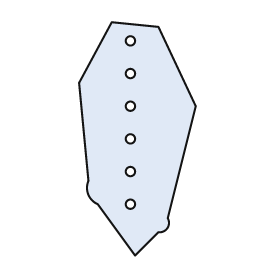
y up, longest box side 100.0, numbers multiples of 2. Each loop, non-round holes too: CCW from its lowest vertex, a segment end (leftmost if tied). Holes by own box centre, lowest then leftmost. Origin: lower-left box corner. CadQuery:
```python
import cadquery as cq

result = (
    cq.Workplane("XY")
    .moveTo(24.0, 0.0)
    .lineTo(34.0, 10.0)
    .threePointArc((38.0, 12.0), (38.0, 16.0))
    .lineTo(50.0, 64.0)
    .lineTo(34.0, 98.0)
    .lineTo(14.0, 100.0)
    .lineTo(0.0, 74.0)
    .lineTo(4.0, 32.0)
    .threePointArc((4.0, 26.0), (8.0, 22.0))
    .close()
    .moveTo(22.0, 22.0)
    .circle(2.0)
    .moveTo(22.0, 36.0)
    .circle(2.0)
    .moveTo(22.0, 50.0)
    .circle(2.0)
    .moveTo(22.0, 64.0)
    .circle(2.0)
    .moveTo(22.0, 78.0)
    .circle(2.0)
    .moveTo(22.0, 92.0)
    .circle(2.0)
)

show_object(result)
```